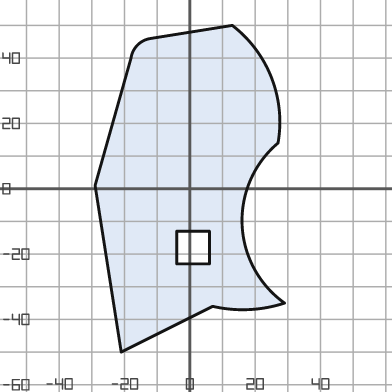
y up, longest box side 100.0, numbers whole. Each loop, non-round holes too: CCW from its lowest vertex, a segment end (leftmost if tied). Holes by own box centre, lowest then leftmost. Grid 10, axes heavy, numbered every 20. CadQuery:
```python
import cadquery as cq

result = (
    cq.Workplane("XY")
    .moveTo(-21.0, -50.0)
    .lineTo(7.0, -36.0)
    .threePointArc((18.0, -37.0), (29.0, -35.0))
    .threePointArc((16.0, -11.0), (27.0, 14.0))
    .threePointArc((25.0, 34.0), (13.0, 50.0))
    .lineTo(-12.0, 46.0)
    .threePointArc((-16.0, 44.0), (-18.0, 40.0))
    .lineTo(-29.0, 1.0)
    .close()
    .moveTo(-4.0, -23.0)
    .lineTo(6.0, -23.0)
    .lineTo(6.0, -13.0)
    .lineTo(-4.0, -13.0)
    .close()
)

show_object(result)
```